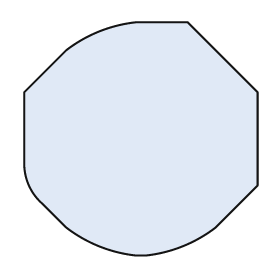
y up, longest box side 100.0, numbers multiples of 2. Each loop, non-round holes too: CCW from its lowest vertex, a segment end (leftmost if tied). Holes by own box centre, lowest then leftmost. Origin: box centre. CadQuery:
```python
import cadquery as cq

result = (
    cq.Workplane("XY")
    .moveTo(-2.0, -50.0)
    .lineTo(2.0, -50.0)
    .threePointArc((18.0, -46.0), (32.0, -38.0))
    .lineTo(50.0, -20.0)
    .lineTo(50.0, 20.0)
    .lineTo(20.0, 50.0)
    .lineTo(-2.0, 50.0)
    .threePointArc((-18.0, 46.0), (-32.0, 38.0))
    .lineTo(-50.0, 20.0)
    .lineTo(-50.0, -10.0)
    .threePointArc((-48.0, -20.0), (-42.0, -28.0))
    .lineTo(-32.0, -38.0)
    .threePointArc((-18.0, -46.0), (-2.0, -50.0))
    .close()
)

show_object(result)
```